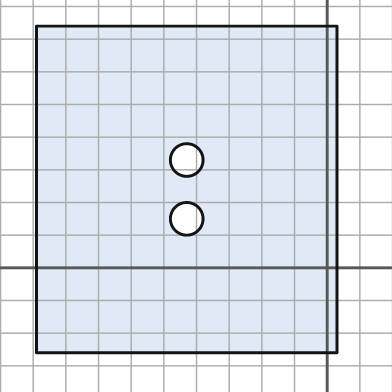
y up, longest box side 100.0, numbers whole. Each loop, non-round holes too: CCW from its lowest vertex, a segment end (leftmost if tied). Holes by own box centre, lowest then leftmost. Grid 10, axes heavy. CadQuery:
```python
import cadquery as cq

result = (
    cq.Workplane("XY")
    .moveTo(-89.0, -26.0)
    .lineTo(3.0, -26.0)
    .lineTo(3.0, 74.0)
    .lineTo(-89.0, 74.0)
    .close()
    .moveTo(-43.0, 15.0)
    .circle(5.0)
    .moveTo(-43.0, 33.0)
    .circle(5.0)
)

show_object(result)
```